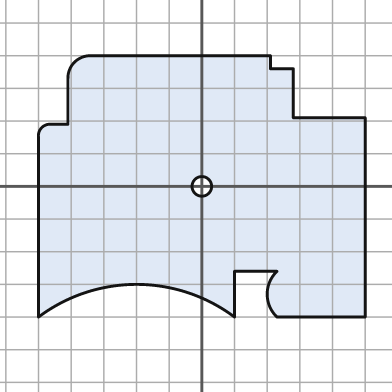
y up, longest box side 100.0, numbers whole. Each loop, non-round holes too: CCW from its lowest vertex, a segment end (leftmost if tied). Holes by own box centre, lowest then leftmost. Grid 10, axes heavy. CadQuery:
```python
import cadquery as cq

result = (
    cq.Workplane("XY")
    .moveTo(-50.0, -40.0)
    .threePointArc((-20.0, -30.0), (10.0, -40.0))
    .lineTo(10.0, -26.0)
    .lineTo(23.0, -26.0)
    .threePointArc((20.0, -33.0), (23.0, -40.0))
    .lineTo(50.0, -40.0)
    .lineTo(50.0, 21.0)
    .lineTo(28.0, 21.0)
    .lineTo(28.0, 36.0)
    .lineTo(21.0, 36.0)
    .lineTo(21.0, 40.0)
    .lineTo(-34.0, 40.0)
    .threePointArc((-39.0, 38.0), (-41.0, 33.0))
    .lineTo(-41.0, 19.0)
    .lineTo(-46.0, 19.0)
    .threePointArc((-49.0, 18.0), (-50.0, 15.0))
    .close()
    .moveTo(0.0, 0.0)
    .circle(3.0)
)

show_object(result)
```